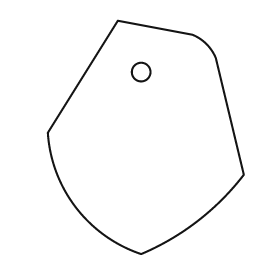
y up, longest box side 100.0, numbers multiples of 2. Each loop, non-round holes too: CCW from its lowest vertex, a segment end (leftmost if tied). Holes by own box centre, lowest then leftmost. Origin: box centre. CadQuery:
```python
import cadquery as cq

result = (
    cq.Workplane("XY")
    .moveTo(-2.0, -50.0)
    .threePointArc((22.0, -36.0), (42.0, -16.0))
    .lineTo(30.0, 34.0)
    .threePointArc((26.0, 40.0), (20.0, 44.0))
    .lineTo(-12.0, 50.0)
    .lineTo(-42.0, 2.0)
    .threePointArc((-30.0, -30.0), (-2.0, -50.0))
    .close()
    .moveTo(-2.0, 28.0)
    .circle(4.0)
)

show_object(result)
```